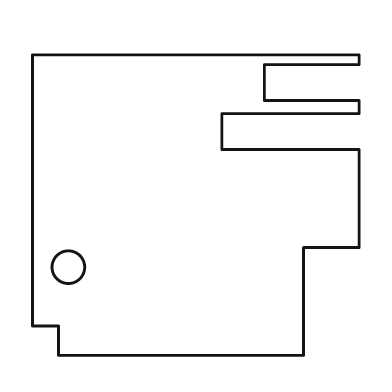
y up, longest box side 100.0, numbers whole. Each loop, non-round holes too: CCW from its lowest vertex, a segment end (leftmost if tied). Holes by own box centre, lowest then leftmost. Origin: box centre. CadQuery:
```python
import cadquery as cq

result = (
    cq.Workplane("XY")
    .moveTo(-42.0, -46.0)
    .lineTo(33.0, -46.0)
    .lineTo(33.0, -13.0)
    .lineTo(50.0, -13.0)
    .lineTo(50.0, 17.0)
    .lineTo(8.0, 17.0)
    .lineTo(8.0, 28.0)
    .lineTo(50.0, 28.0)
    .lineTo(50.0, 32.0)
    .lineTo(21.0, 32.0)
    .lineTo(21.0, 43.0)
    .lineTo(50.0, 43.0)
    .lineTo(50.0, 46.0)
    .lineTo(-50.0, 46.0)
    .lineTo(-50.0, -37.0)
    .lineTo(-42.0, -37.0)
    .close()
    .moveTo(-39.0, -19.0)
    .circle(5.0)
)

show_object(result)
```